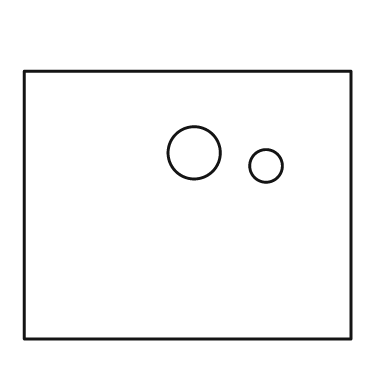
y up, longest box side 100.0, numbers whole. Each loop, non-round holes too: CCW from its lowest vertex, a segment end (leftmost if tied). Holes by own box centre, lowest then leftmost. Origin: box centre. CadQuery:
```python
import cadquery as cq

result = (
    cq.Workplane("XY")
    .moveTo(-50.0, -41.0)
    .lineTo(50.0, -41.0)
    .lineTo(50.0, 41.0)
    .lineTo(-50.0, 41.0)
    .close()
    .moveTo(24.0, 12.0)
    .circle(5.0)
    .moveTo(2.0, 16.0)
    .circle(8.0)
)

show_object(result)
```